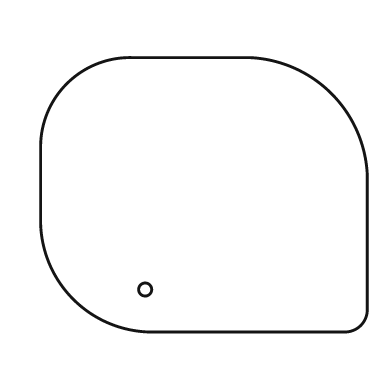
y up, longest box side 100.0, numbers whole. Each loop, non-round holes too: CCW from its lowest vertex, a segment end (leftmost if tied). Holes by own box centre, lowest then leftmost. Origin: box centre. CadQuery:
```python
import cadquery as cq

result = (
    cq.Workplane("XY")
    .moveTo(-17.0, -42.0)
    .lineTo(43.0, -42.0)
    .threePointArc((48.0, -40.0), (50.0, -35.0))
    .lineTo(50.0, 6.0)
    .threePointArc((39.0, 31.0), (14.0, 42.0))
    .lineTo(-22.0, 42.0)
    .threePointArc((-42.0, 34.0), (-50.0, 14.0))
    .lineTo(-50.0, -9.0)
    .threePointArc((-40.0, -32.0), (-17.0, -42.0))
    .close()
    .moveTo(-18.0, -29.0)
    .circle(2.0)
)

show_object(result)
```